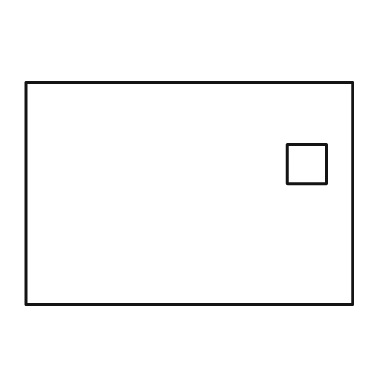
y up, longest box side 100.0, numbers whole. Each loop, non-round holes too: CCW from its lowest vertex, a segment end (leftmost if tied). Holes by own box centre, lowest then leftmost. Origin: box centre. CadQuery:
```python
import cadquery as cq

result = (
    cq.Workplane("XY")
    .moveTo(-50.0, -34.0)
    .lineTo(50.0, -34.0)
    .lineTo(50.0, 34.0)
    .lineTo(-50.0, 34.0)
    .close()
    .moveTo(30.0, 3.0)
    .lineTo(42.0, 3.0)
    .lineTo(42.0, 15.0)
    .lineTo(30.0, 15.0)
    .close()
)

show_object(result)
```